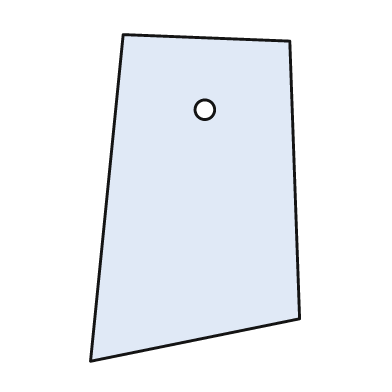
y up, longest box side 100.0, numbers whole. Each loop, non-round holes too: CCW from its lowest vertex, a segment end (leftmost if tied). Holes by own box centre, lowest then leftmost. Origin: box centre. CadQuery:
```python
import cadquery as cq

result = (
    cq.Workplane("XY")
    .moveTo(-32.0, -50.0)
    .lineTo(32.0, -37.0)
    .lineTo(29.0, 48.0)
    .lineTo(-22.0, 50.0)
    .close()
    .moveTo(3.0, 27.0)
    .circle(3.0)
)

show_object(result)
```